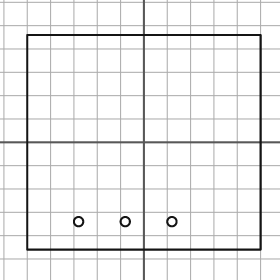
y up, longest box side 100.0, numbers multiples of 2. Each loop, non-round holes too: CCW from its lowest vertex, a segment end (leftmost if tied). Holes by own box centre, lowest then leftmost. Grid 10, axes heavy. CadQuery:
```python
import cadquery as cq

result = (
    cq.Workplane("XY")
    .moveTo(-50.0, -46.0)
    .lineTo(50.0, -46.0)
    .lineTo(50.0, 46.0)
    .lineTo(-50.0, 46.0)
    .close()
    .moveTo(-28.0, -34.0)
    .circle(2.0)
    .moveTo(-8.0, -34.0)
    .circle(2.0)
    .moveTo(12.0, -34.0)
    .circle(2.0)
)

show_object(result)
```